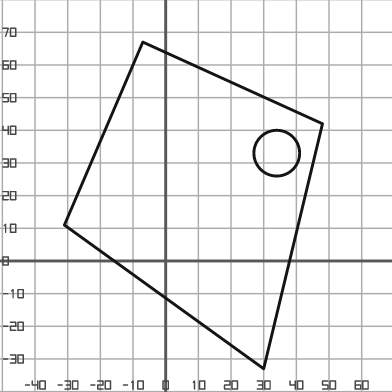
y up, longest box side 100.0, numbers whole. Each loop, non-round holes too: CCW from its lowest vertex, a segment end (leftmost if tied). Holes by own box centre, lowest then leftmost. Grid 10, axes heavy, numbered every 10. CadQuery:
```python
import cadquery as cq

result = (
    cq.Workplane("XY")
    .moveTo(30.0, -33.0)
    .lineTo(48.0, 42.0)
    .lineTo(-7.0, 67.0)
    .lineTo(-31.0, 11.0)
    .close()
    .moveTo(34.0, 33.0)
    .circle(7.0)
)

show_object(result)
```